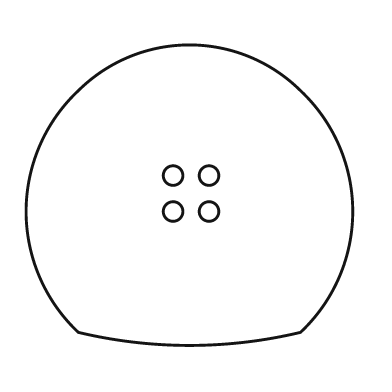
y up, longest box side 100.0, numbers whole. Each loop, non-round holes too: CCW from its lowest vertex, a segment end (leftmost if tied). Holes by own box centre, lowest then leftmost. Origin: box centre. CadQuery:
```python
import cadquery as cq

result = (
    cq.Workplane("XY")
    .moveTo(-34.0, -42.0)
    .threePointArc((0.0, -46.0), (34.0, -42.0))
    .threePointArc((50.0, -5.0), (34.0, 32.0))
    .threePointArc((0.0, 46.0), (-34.0, 32.0))
    .threePointArc((-50.0, -5.0), (-34.0, -42.0))
    .close()
    .moveTo(-5.0, -5.0)
    .circle(3.0)
    .moveTo(6.0, -5.0)
    .circle(3.0)
    .moveTo(-5.0, 6.0)
    .circle(3.0)
    .moveTo(6.0, 6.0)
    .circle(3.0)
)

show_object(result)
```